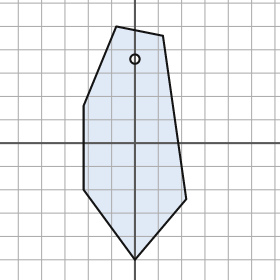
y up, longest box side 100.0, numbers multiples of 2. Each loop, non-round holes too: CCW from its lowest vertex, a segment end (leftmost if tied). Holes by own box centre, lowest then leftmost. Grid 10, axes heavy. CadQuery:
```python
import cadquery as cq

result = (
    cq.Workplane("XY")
    .moveTo(0.0, -50.0)
    .lineTo(22.0, -24.0)
    .lineTo(12.0, 46.0)
    .lineTo(-8.0, 50.0)
    .lineTo(-22.0, 16.0)
    .lineTo(-22.0, -20.0)
    .close()
    .moveTo(0.0, 36.0)
    .circle(2.0)
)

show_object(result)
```